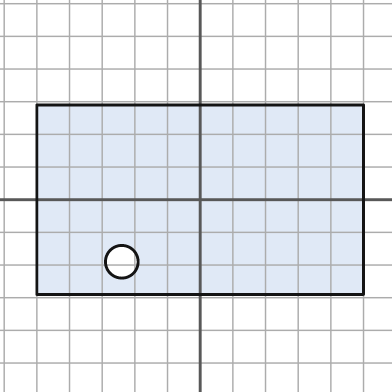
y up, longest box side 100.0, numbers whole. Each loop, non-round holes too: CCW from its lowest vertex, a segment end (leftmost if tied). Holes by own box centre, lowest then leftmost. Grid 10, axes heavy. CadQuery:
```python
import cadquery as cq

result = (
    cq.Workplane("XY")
    .moveTo(-50.0, -29.0)
    .lineTo(50.0, -29.0)
    .lineTo(50.0, 29.0)
    .lineTo(-50.0, 29.0)
    .close()
    .moveTo(-24.0, -19.0)
    .circle(5.0)
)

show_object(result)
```